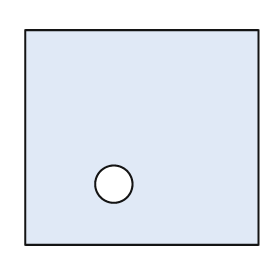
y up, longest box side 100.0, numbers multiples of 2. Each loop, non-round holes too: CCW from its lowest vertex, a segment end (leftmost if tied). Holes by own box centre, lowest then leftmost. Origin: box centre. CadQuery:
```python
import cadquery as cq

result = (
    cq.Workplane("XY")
    .moveTo(-50.0, -46.0)
    .lineTo(50.0, -46.0)
    .lineTo(50.0, 46.0)
    .lineTo(-50.0, 46.0)
    .close()
    .moveTo(-12.0, -20.0)
    .circle(8.0)
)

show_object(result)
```